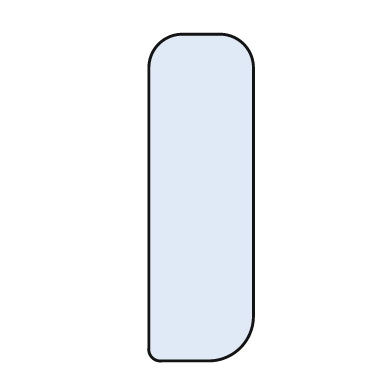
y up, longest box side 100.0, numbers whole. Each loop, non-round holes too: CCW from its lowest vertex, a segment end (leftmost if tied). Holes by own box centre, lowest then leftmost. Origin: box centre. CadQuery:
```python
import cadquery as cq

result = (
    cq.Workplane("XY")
    .moveTo(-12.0, -50.0)
    .lineTo(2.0, -50.0)
    .threePointArc((12.0, -46.0), (16.0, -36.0))
    .lineTo(16.0, 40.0)
    .threePointArc((13.0, 47.0), (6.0, 50.0))
    .lineTo(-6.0, 50.0)
    .threePointArc((-13.0, 47.0), (-16.0, 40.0))
    .lineTo(-16.0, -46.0)
    .threePointArc((-15.0, -49.0), (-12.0, -50.0))
    .close()
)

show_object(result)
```